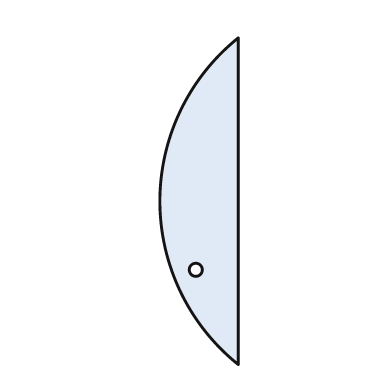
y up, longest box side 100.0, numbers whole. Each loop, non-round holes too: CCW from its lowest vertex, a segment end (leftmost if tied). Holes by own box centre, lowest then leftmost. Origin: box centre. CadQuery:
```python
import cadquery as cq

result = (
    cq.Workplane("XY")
    .moveTo(12.0, -50.0)
    .lineTo(12.0, 50.0)
    .threePointArc((-12.0, 0.0), (12.0, -50.0))
    .close()
    .moveTo(-1.0, -21.0)
    .circle(2.0)
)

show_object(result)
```